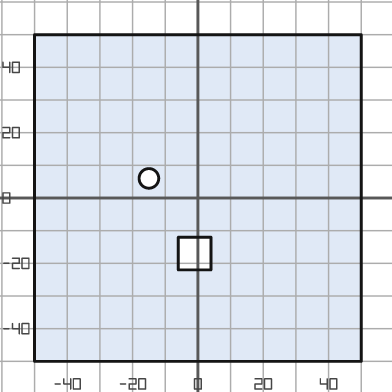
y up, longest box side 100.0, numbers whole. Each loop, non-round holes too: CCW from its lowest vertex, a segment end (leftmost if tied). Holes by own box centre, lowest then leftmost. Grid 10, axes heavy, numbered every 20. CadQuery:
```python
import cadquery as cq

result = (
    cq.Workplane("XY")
    .moveTo(-50.0, -50.0)
    .lineTo(50.0, -50.0)
    .lineTo(50.0, 50.0)
    .lineTo(-50.0, 50.0)
    .close()
    .moveTo(-6.0, -22.0)
    .lineTo(4.0, -22.0)
    .lineTo(4.0, -12.0)
    .lineTo(-6.0, -12.0)
    .close()
    .moveTo(-15.0, 6.0)
    .circle(3.0)
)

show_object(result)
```